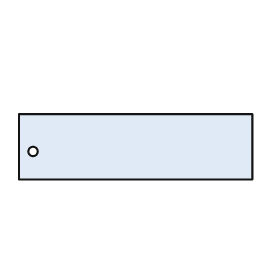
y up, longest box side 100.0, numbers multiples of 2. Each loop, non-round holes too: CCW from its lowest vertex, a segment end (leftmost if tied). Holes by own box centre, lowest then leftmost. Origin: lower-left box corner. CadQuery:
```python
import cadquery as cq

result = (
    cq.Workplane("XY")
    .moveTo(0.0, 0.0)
    .lineTo(100.0, 0.0)
    .lineTo(100.0, 28.0)
    .lineTo(0.0, 28.0)
    .close()
    .moveTo(6.0, 12.0)
    .circle(2.0)
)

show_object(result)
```